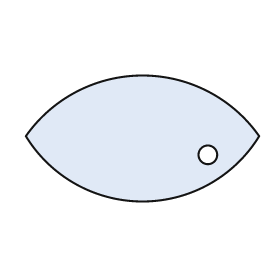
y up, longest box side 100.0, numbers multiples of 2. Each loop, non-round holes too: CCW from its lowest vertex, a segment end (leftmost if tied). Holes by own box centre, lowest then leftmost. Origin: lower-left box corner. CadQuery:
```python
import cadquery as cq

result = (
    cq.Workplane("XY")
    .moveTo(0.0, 28.0)
    .threePointArc((50.0, 0.0), (100.0, 28.0))
    .threePointArc((50.0, 54.0), (0.0, 28.0))
    .close()
    .moveTo(78.0, 20.0)
    .circle(4.0)
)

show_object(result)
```